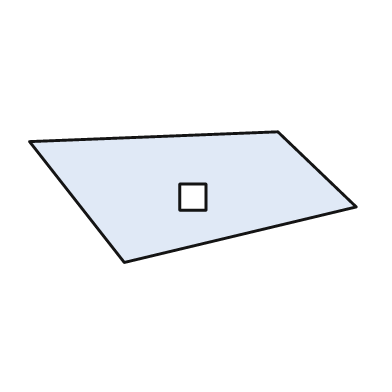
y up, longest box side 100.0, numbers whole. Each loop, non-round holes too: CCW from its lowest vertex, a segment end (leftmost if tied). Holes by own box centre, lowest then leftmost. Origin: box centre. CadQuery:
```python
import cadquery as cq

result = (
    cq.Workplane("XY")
    .moveTo(-21.0, -20.0)
    .lineTo(50.0, -3.0)
    .lineTo(26.0, 20.0)
    .lineTo(-50.0, 17.0)
    .close()
    .moveTo(-4.0, -4.0)
    .lineTo(4.0, -4.0)
    .lineTo(4.0, 4.0)
    .lineTo(-4.0, 4.0)
    .close()
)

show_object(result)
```